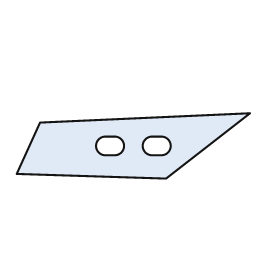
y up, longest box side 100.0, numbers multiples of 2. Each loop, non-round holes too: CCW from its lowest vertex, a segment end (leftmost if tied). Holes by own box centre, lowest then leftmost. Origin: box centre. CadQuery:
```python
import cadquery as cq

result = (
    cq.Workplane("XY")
    .moveTo(14.0, -14.0)
    .lineTo(50.0, 14.0)
    .lineTo(-40.0, 10.0)
    .lineTo(-50.0, -12.0)
    .close()
    .moveTo(-12.0, -4.0)
    .lineTo(-8.0, -4.0)
    .threePointArc((-4.0, 0.0), (-8.0, 4.0))
    .lineTo(-12.0, 4.0)
    .threePointArc((-16.0, 0.0), (-12.0, -4.0))
    .close()
    .moveTo(8.0, -4.0)
    .lineTo(12.0, -4.0)
    .threePointArc((16.0, 0.0), (12.0, 4.0))
    .lineTo(8.0, 4.0)
    .threePointArc((4.0, 0.0), (8.0, -4.0))
    .close()
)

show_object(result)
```